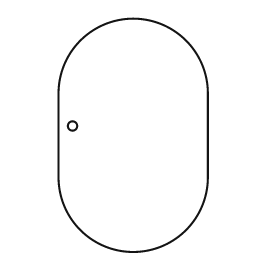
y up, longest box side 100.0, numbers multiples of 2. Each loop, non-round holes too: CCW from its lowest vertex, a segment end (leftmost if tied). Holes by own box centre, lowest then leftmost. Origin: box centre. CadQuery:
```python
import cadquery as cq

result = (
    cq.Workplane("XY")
    .moveTo(-32.0, -18.0)
    .threePointArc((0.0, -50.0), (32.0, -18.0))
    .lineTo(32.0, 18.0)
    .threePointArc((0.0, 50.0), (-32.0, 18.0))
    .close()
    .moveTo(-26.0, 4.0)
    .circle(2.0)
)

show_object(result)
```